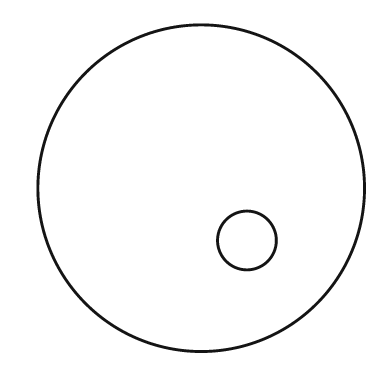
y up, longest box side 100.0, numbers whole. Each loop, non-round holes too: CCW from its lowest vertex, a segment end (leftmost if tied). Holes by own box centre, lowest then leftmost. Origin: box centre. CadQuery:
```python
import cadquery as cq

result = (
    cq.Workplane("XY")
    .moveTo(0.0, 0.0)
    .circle(50.0)
    .moveTo(14.0, -16.0)
    .circle(9.0)
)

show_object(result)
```